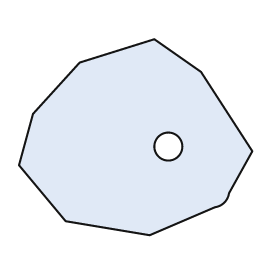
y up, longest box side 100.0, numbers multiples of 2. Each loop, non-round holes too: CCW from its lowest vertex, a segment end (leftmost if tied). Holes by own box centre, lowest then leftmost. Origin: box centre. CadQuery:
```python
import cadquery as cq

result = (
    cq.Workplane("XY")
    .moveTo(6.0, -42.0)
    .lineTo(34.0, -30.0)
    .threePointArc((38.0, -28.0), (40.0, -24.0))
    .lineTo(50.0, -6.0)
    .lineTo(28.0, 28.0)
    .lineTo(8.0, 42.0)
    .lineTo(-24.0, 32.0)
    .lineTo(-44.0, 10.0)
    .lineTo(-50.0, -12.0)
    .lineTo(-30.0, -36.0)
    .close()
    .moveTo(14.0, -4.0)
    .circle(6.0)
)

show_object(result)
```